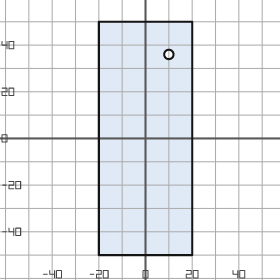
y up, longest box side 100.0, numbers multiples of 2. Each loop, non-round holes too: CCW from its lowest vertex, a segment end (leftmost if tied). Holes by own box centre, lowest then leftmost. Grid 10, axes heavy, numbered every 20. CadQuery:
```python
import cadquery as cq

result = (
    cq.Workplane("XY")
    .moveTo(-20.0, -50.0)
    .lineTo(20.0, -50.0)
    .lineTo(20.0, 50.0)
    .lineTo(-20.0, 50.0)
    .close()
    .moveTo(10.0, 36.0)
    .circle(2.0)
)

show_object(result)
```